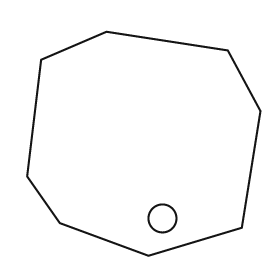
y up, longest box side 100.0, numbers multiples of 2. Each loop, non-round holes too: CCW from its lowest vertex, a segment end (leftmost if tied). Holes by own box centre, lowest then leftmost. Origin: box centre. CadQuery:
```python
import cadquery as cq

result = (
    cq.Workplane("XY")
    .moveTo(2.0, -48.0)
    .lineTo(42.0, -36.0)
    .lineTo(50.0, 14.0)
    .lineTo(36.0, 40.0)
    .lineTo(-16.0, 48.0)
    .lineTo(-44.0, 36.0)
    .lineTo(-50.0, -14.0)
    .lineTo(-36.0, -34.0)
    .close()
    .moveTo(8.0, -32.0)
    .circle(6.0)
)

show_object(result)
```